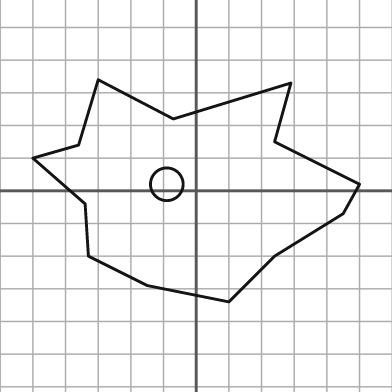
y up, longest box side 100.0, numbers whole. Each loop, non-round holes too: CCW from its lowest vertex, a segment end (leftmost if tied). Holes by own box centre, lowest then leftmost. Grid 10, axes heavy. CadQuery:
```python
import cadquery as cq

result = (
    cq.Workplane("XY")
    .moveTo(10.0, -34.0)
    .lineTo(24.0, -20.0)
    .lineTo(45.0, -7.0)
    .lineTo(50.0, 2.0)
    .lineTo(24.0, 15.0)
    .lineTo(29.0, 33.0)
    .lineTo(-7.0, 22.0)
    .lineTo(-30.0, 34.0)
    .lineTo(-36.0, 14.0)
    .lineTo(-50.0, 10.0)
    .lineTo(-34.0, -4.0)
    .lineTo(-33.0, -20.0)
    .lineTo(-15.0, -29.0)
    .close()
    .moveTo(-9.0, 2.0)
    .circle(5.0)
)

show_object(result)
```